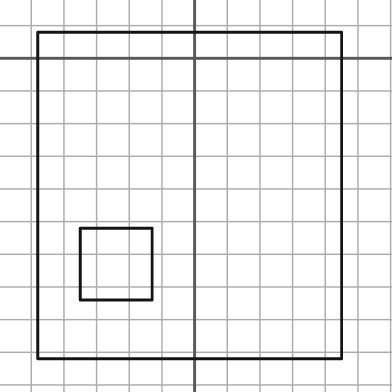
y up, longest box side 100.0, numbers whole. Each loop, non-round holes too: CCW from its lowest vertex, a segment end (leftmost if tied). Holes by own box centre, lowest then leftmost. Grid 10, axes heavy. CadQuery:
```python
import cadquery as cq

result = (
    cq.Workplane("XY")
    .moveTo(-48.0, -92.0)
    .lineTo(45.0, -92.0)
    .lineTo(45.0, 8.0)
    .lineTo(-48.0, 8.0)
    .close()
    .moveTo(-35.0, -74.0)
    .lineTo(-13.0, -74.0)
    .lineTo(-13.0, -52.0)
    .lineTo(-35.0, -52.0)
    .close()
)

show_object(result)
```